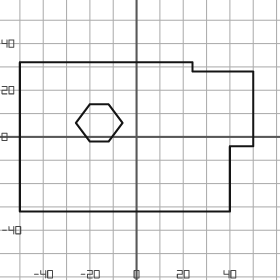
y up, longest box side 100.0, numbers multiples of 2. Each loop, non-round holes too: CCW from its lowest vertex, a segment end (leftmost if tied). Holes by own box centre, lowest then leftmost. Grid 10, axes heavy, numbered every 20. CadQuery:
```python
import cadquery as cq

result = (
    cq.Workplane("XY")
    .moveTo(-50.0, -32.0)
    .lineTo(40.0, -32.0)
    .lineTo(40.0, -4.0)
    .lineTo(50.0, -4.0)
    .lineTo(50.0, 28.0)
    .lineTo(24.0, 28.0)
    .lineTo(24.0, 32.0)
    .lineTo(-50.0, 32.0)
    .close()
    .moveTo(-20.0, -2.0)
    .lineTo(-12.0, -2.0)
    .lineTo(-6.0, 6.0)
    .lineTo(-12.0, 14.0)
    .lineTo(-20.0, 14.0)
    .lineTo(-26.0, 6.0)
    .close()
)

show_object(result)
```